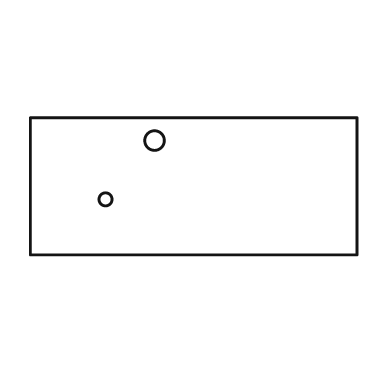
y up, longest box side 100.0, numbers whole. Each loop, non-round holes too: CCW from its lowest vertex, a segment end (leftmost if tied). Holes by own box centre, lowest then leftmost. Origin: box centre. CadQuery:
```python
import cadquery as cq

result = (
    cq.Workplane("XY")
    .moveTo(-50.0, -21.0)
    .lineTo(50.0, -21.0)
    .lineTo(50.0, 21.0)
    .lineTo(-50.0, 21.0)
    .close()
    .moveTo(-27.0, -4.0)
    .circle(2.0)
    .moveTo(-12.0, 14.0)
    .circle(3.0)
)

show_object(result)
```